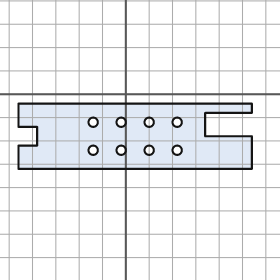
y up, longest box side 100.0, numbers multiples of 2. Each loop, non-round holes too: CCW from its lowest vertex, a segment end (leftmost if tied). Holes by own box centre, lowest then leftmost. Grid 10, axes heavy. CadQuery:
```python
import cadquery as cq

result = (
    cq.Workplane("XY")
    .moveTo(-46.0, -32.0)
    .lineTo(54.0, -32.0)
    .lineTo(54.0, -18.0)
    .lineTo(34.0, -18.0)
    .lineTo(34.0, -8.0)
    .lineTo(54.0, -8.0)
    .lineTo(54.0, -4.0)
    .lineTo(-46.0, -4.0)
    .lineTo(-46.0, -14.0)
    .lineTo(-38.0, -14.0)
    .lineTo(-38.0, -22.0)
    .lineTo(-46.0, -22.0)
    .close()
    .moveTo(-14.0, -24.0)
    .circle(2.0)
    .moveTo(-2.0, -24.0)
    .circle(2.0)
    .moveTo(10.0, -24.0)
    .circle(2.0)
    .moveTo(22.0, -24.0)
    .circle(2.0)
    .moveTo(-14.0, -12.0)
    .circle(2.0)
    .moveTo(-2.0, -12.0)
    .circle(2.0)
    .moveTo(10.0, -12.0)
    .circle(2.0)
    .moveTo(22.0, -12.0)
    .circle(2.0)
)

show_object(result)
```